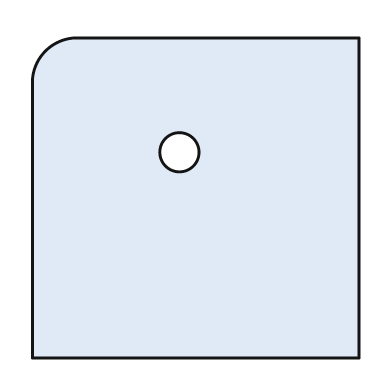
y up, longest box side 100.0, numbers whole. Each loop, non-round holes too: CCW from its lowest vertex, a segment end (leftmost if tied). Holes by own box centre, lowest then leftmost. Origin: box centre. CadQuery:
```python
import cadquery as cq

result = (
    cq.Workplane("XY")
    .moveTo(-50.0, -49.0)
    .lineTo(50.0, -49.0)
    .lineTo(50.0, 49.0)
    .lineTo(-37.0, 49.0)
    .threePointArc((-46.0, 45.0), (-50.0, 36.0))
    .close()
    .moveTo(-5.0, 14.0)
    .circle(6.0)
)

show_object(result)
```